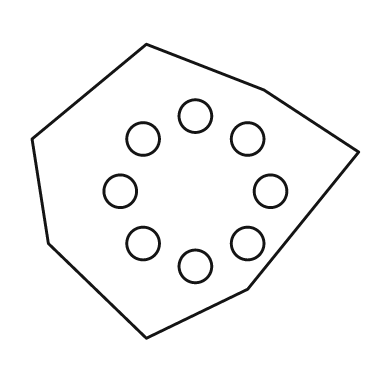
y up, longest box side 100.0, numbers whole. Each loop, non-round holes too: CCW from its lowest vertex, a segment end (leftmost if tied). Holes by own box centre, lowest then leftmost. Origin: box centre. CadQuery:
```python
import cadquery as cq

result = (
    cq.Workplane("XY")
    .moveTo(-15.0, -45.0)
    .lineTo(16.0, -30.0)
    .lineTo(50.0, 12.0)
    .lineTo(21.0, 31.0)
    .lineTo(-15.0, 45.0)
    .lineTo(-50.0, 16.0)
    .lineTo(-45.0, -16.0)
    .close()
    .moveTo(0.0, -23.0)
    .circle(5.0)
    .moveTo(-16.0, -16.0)
    .circle(5.0)
    .moveTo(16.0, -16.0)
    .circle(5.0)
    .moveTo(-23.0, 0.0)
    .circle(5.0)
    .moveTo(23.0, 0.0)
    .circle(5.0)
    .moveTo(-16.0, 16.0)
    .circle(5.0)
    .moveTo(16.0, 16.0)
    .circle(5.0)
    .moveTo(0.0, 23.0)
    .circle(5.0)
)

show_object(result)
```